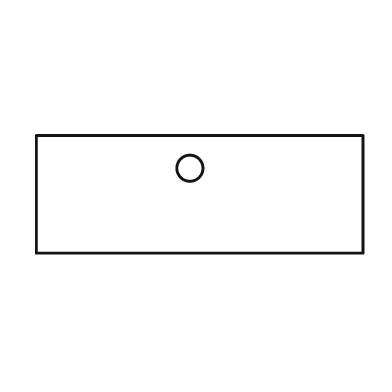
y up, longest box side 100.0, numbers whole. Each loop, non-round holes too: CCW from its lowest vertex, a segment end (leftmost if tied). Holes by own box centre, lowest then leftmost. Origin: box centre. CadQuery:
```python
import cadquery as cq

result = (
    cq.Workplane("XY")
    .moveTo(-50.0, -18.0)
    .lineTo(50.0, -18.0)
    .lineTo(50.0, 18.0)
    .lineTo(-50.0, 18.0)
    .close()
    .moveTo(-3.0, 8.0)
    .circle(4.0)
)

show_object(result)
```